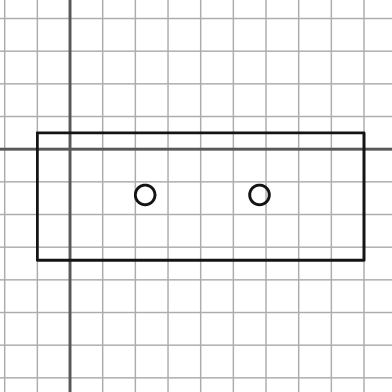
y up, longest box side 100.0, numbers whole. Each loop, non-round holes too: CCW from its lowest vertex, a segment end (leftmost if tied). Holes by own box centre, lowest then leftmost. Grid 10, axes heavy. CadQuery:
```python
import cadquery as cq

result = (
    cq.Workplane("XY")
    .moveTo(-10.0, -34.0)
    .lineTo(90.0, -34.0)
    .lineTo(90.0, 5.0)
    .lineTo(-10.0, 5.0)
    .close()
    .moveTo(23.0, -14.0)
    .circle(3.0)
    .moveTo(58.0, -14.0)
    .circle(3.0)
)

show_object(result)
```